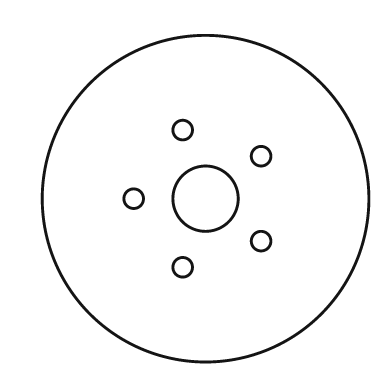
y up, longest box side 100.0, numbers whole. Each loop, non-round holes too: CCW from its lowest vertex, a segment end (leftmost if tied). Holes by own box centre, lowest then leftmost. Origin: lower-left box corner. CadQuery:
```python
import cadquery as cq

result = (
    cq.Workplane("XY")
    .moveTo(50.0, 50.0)
    .circle(50.0)
    .moveTo(43.0, 29.0)
    .circle(3.0)
    .moveTo(67.0, 37.0)
    .circle(3.0)
    .moveTo(28.0, 50.0)
    .circle(3.0)
    .moveTo(50.0, 50.0)
    .circle(10.0)
    .moveTo(67.0, 63.0)
    .circle(3.0)
    .moveTo(43.0, 71.0)
    .circle(3.0)
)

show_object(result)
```